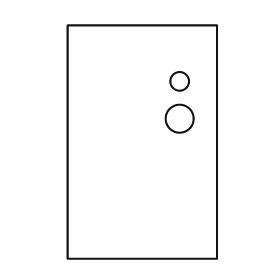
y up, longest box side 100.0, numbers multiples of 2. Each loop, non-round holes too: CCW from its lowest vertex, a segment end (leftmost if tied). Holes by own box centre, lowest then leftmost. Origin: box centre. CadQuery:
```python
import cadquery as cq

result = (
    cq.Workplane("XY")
    .moveTo(-32.0, -50.0)
    .lineTo(32.0, -50.0)
    .lineTo(32.0, 50.0)
    .lineTo(-32.0, 50.0)
    .close()
    .moveTo(16.0, 10.0)
    .circle(6.0)
    .moveTo(16.0, 26.0)
    .circle(4.0)
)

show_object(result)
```